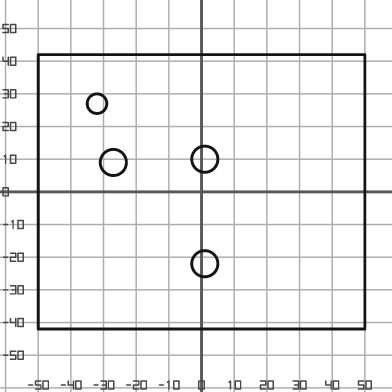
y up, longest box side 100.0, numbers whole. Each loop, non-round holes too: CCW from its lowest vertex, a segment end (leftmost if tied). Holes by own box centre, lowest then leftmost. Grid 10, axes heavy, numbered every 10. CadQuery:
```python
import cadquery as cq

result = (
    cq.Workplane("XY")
    .moveTo(-50.0, -42.0)
    .lineTo(50.0, -42.0)
    .lineTo(50.0, 42.0)
    .lineTo(-50.0, 42.0)
    .close()
    .moveTo(1.0, -22.0)
    .circle(4.0)
    .moveTo(-27.0, 9.0)
    .circle(4.0)
    .moveTo(1.0, 10.0)
    .circle(4.0)
    .moveTo(-32.0, 27.0)
    .circle(3.0)
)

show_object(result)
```